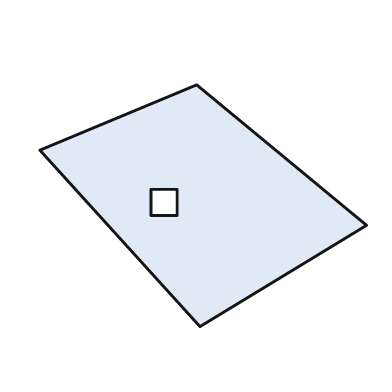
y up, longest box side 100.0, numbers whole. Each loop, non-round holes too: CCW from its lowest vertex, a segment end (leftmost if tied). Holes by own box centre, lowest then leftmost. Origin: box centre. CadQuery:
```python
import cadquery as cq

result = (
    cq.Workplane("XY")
    .moveTo(-1.0, -37.0)
    .lineTo(50.0, -6.0)
    .lineTo(-2.0, 37.0)
    .lineTo(-50.0, 17.0)
    .close()
    .moveTo(-16.0, -3.0)
    .lineTo(-8.0, -3.0)
    .lineTo(-8.0, 5.0)
    .lineTo(-16.0, 5.0)
    .close()
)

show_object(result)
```